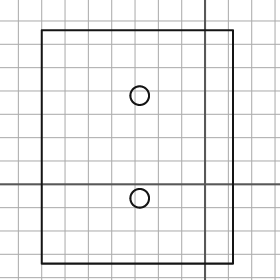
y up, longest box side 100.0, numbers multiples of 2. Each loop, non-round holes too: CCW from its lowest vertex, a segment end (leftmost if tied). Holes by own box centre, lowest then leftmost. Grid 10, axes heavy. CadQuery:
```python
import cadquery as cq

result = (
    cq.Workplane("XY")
    .moveTo(-70.0, -34.0)
    .lineTo(12.0, -34.0)
    .lineTo(12.0, 66.0)
    .lineTo(-70.0, 66.0)
    .close()
    .moveTo(-28.0, -6.0)
    .circle(4.0)
    .moveTo(-28.0, 38.0)
    .circle(4.0)
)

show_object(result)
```